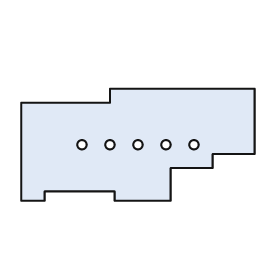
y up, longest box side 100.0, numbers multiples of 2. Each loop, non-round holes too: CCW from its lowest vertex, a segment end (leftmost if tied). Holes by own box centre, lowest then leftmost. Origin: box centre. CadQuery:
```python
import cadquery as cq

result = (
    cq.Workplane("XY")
    .moveTo(-50.0, -24.0)
    .lineTo(-40.0, -24.0)
    .lineTo(-40.0, -20.0)
    .lineTo(-10.0, -20.0)
    .lineTo(-10.0, -24.0)
    .lineTo(14.0, -24.0)
    .lineTo(14.0, -10.0)
    .lineTo(32.0, -10.0)
    .lineTo(32.0, -4.0)
    .lineTo(50.0, -4.0)
    .lineTo(50.0, 24.0)
    .lineTo(-12.0, 24.0)
    .lineTo(-12.0, 18.0)
    .lineTo(-50.0, 18.0)
    .close()
    .moveTo(-24.0, 0.0)
    .circle(2.0)
    .moveTo(-12.0, 0.0)
    .circle(2.0)
    .moveTo(0.0, 0.0)
    .circle(2.0)
    .moveTo(12.0, 0.0)
    .circle(2.0)
    .moveTo(24.0, 0.0)
    .circle(2.0)
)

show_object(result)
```